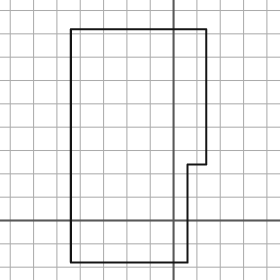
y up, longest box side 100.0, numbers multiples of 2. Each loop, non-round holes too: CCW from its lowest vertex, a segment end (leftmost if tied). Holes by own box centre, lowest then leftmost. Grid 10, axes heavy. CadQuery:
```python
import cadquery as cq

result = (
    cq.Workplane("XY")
    .moveTo(-44.0, -18.0)
    .lineTo(6.0, -18.0)
    .lineTo(6.0, 24.0)
    .lineTo(14.0, 24.0)
    .lineTo(14.0, 82.0)
    .lineTo(-44.0, 82.0)
    .close()
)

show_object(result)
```